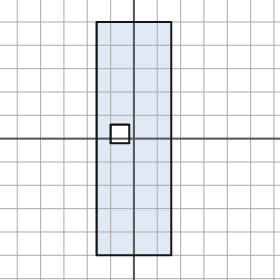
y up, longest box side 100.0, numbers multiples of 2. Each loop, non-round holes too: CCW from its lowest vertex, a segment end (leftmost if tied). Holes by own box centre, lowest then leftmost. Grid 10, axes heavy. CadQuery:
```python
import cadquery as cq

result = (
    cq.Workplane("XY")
    .moveTo(-16.0, -50.0)
    .lineTo(16.0, -50.0)
    .lineTo(16.0, 50.0)
    .lineTo(-16.0, 50.0)
    .close()
    .moveTo(-10.0, -2.0)
    .lineTo(-2.0, -2.0)
    .lineTo(-2.0, 6.0)
    .lineTo(-10.0, 6.0)
    .close()
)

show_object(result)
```